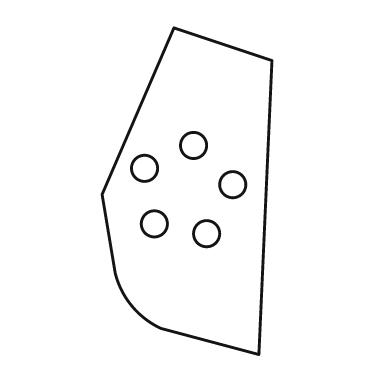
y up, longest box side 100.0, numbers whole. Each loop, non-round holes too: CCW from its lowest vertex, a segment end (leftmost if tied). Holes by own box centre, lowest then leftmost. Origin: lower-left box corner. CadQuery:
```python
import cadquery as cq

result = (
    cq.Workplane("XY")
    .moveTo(48.0, 0.0)
    .lineTo(52.0, 90.0)
    .lineTo(22.0, 100.0)
    .lineTo(0.0, 49.0)
    .lineTo(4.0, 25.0)
    .threePointArc((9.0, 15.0), (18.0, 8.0))
    .close()
    .moveTo(32.0, 37.0)
    .circle(4.0)
    .moveTo(16.0, 40.0)
    .circle(4.0)
    .moveTo(40.0, 52.0)
    .circle(4.0)
    .moveTo(13.0, 57.0)
    .circle(4.0)
    .moveTo(28.0, 64.0)
    .circle(4.0)
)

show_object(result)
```